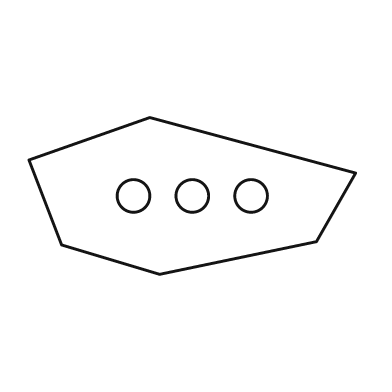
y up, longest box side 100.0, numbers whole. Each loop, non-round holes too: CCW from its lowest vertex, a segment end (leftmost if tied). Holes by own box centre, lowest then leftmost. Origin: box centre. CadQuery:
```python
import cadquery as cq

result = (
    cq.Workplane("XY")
    .moveTo(-10.0, -24.0)
    .lineTo(38.0, -14.0)
    .lineTo(50.0, 7.0)
    .lineTo(-13.0, 24.0)
    .lineTo(-50.0, 11.0)
    .lineTo(-40.0, -15.0)
    .close()
    .moveTo(-18.0, 0.0)
    .circle(5.0)
    .moveTo(0.0, 0.0)
    .circle(5.0)
    .moveTo(18.0, 0.0)
    .circle(5.0)
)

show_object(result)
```